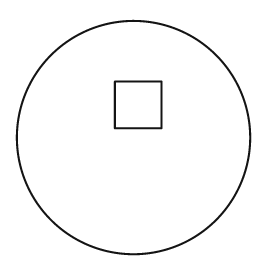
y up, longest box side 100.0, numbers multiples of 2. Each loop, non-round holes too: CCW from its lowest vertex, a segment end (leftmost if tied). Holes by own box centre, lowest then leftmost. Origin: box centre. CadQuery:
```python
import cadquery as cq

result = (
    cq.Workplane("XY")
    .moveTo(0.0, 0.0)
    .circle(50.0)
    .moveTo(-8.0, 4.0)
    .lineTo(12.0, 4.0)
    .lineTo(12.0, 24.0)
    .lineTo(-8.0, 24.0)
    .close()
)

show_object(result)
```